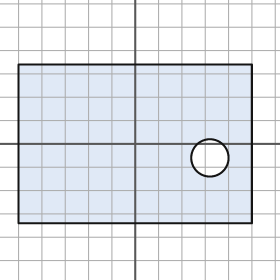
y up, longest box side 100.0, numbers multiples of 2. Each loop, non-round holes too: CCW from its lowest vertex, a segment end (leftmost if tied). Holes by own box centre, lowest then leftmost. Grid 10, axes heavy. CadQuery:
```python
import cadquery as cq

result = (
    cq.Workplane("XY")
    .moveTo(-50.0, -34.0)
    .lineTo(50.0, -34.0)
    .lineTo(50.0, 34.0)
    .lineTo(-50.0, 34.0)
    .close()
    .moveTo(32.0, -6.0)
    .circle(8.0)
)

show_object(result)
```